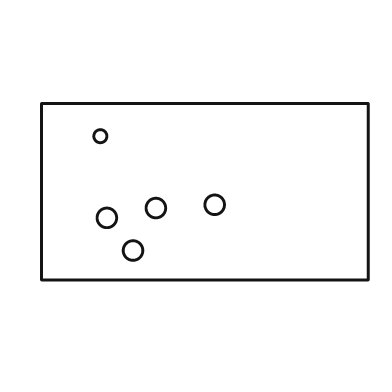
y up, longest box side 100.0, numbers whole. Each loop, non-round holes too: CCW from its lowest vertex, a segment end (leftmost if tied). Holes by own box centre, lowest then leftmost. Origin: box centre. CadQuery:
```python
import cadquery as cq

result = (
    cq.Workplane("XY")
    .moveTo(-50.0, -27.0)
    .lineTo(50.0, -27.0)
    .lineTo(50.0, 27.0)
    .lineTo(-50.0, 27.0)
    .close()
    .moveTo(-22.0, -18.0)
    .circle(3.0)
    .moveTo(-30.0, -8.0)
    .circle(3.0)
    .moveTo(-15.0, -5.0)
    .circle(3.0)
    .moveTo(3.0, -4.0)
    .circle(3.0)
    .moveTo(-32.0, 17.0)
    .circle(2.0)
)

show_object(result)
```